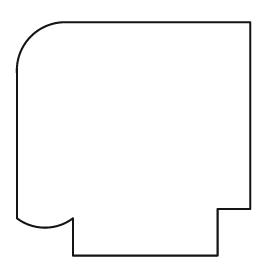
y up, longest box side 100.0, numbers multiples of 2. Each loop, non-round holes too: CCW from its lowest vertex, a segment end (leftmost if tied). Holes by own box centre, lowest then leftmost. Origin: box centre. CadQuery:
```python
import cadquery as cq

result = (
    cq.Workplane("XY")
    .moveTo(-26.0, -50.0)
    .lineTo(36.0, -50.0)
    .lineTo(36.0, -30.0)
    .lineTo(50.0, -30.0)
    .lineTo(50.0, 50.0)
    .lineTo(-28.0, 50.0)
    .threePointArc((-44.0, 44.0), (-50.0, 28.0))
    .lineTo(-50.0, -34.0)
    .threePointArc((-38.0, -38.0), (-26.0, -34.0))
    .close()
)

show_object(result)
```